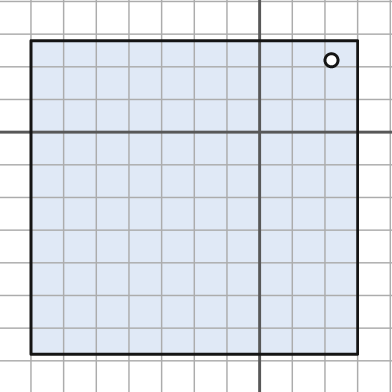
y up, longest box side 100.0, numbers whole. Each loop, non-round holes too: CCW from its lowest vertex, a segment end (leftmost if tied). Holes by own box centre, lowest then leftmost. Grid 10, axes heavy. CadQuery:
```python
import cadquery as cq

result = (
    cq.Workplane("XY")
    .moveTo(-70.0, -68.0)
    .lineTo(30.0, -68.0)
    .lineTo(30.0, 28.0)
    .lineTo(-70.0, 28.0)
    .close()
    .moveTo(22.0, 22.0)
    .circle(2.0)
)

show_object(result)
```